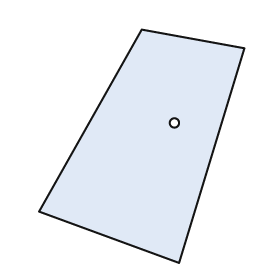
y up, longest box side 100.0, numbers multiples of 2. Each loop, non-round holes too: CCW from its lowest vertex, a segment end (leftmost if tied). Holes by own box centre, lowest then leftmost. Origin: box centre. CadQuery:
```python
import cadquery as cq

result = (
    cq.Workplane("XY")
    .moveTo(16.0, -50.0)
    .lineTo(44.0, 42.0)
    .lineTo(0.0, 50.0)
    .lineTo(-44.0, -28.0)
    .close()
    .moveTo(14.0, 10.0)
    .circle(2.0)
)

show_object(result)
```